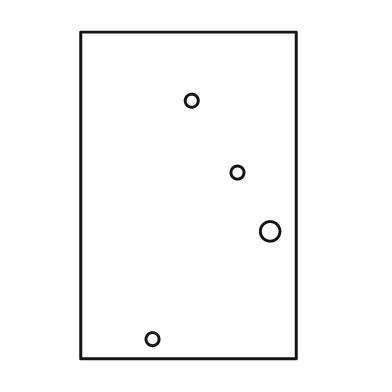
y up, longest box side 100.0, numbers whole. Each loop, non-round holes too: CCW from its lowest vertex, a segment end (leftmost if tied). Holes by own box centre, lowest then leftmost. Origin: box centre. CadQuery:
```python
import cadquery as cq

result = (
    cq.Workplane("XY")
    .moveTo(-33.0, -50.0)
    .lineTo(33.0, -50.0)
    .lineTo(33.0, 50.0)
    .lineTo(-33.0, 50.0)
    .close()
    .moveTo(-11.0, -44.0)
    .circle(2.0)
    .moveTo(25.0, -11.0)
    .circle(3.0)
    .moveTo(15.0, 7.0)
    .circle(2.0)
    .moveTo(1.0, 29.0)
    .circle(2.0)
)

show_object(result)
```